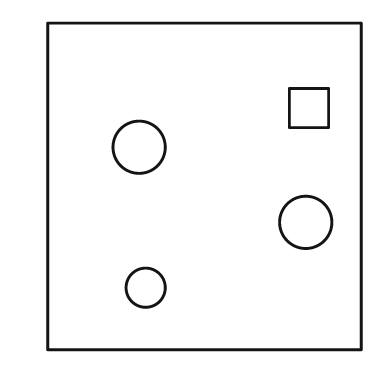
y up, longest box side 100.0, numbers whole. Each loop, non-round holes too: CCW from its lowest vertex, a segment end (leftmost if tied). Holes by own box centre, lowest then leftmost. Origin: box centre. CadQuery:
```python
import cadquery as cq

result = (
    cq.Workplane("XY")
    .moveTo(-48.0, -50.0)
    .lineTo(48.0, -50.0)
    .lineTo(48.0, 50.0)
    .lineTo(-48.0, 50.0)
    .close()
    .moveTo(-18.0, -31.0)
    .circle(6.0)
    .moveTo(31.0, -11.0)
    .circle(8.0)
    .moveTo(-20.0, 12.0)
    .circle(8.0)
    .moveTo(26.0, 18.0)
    .lineTo(38.0, 18.0)
    .lineTo(38.0, 30.0)
    .lineTo(26.0, 30.0)
    .close()
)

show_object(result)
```